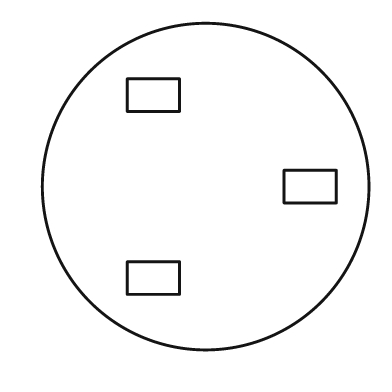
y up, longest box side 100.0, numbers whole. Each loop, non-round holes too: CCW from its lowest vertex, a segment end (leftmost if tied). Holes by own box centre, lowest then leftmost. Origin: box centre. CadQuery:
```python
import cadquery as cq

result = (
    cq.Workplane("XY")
    .moveTo(0.0, 0.0)
    .circle(50.0)
    .moveTo(-24.0, -33.0)
    .lineTo(-8.0, -33.0)
    .lineTo(-8.0, -23.0)
    .lineTo(-24.0, -23.0)
    .close()
    .moveTo(24.0, -5.0)
    .lineTo(40.0, -5.0)
    .lineTo(40.0, 5.0)
    .lineTo(24.0, 5.0)
    .close()
    .moveTo(-24.0, 23.0)
    .lineTo(-8.0, 23.0)
    .lineTo(-8.0, 33.0)
    .lineTo(-24.0, 33.0)
    .close()
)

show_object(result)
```